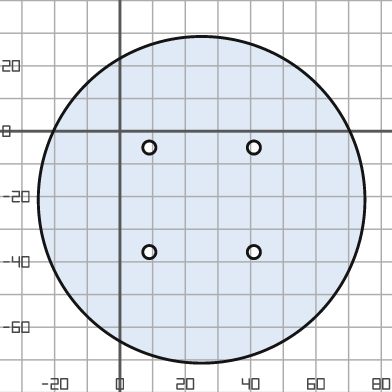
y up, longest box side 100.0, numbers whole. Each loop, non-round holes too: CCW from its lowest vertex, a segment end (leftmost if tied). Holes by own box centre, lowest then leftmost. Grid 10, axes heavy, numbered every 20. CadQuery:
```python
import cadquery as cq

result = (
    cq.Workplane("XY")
    .moveTo(25.0, -21.0)
    .circle(50.0)
    .moveTo(9.0, -37.0)
    .circle(2.0)
    .moveTo(41.0, -37.0)
    .circle(2.0)
    .moveTo(9.0, -5.0)
    .circle(2.0)
    .moveTo(41.0, -5.0)
    .circle(2.0)
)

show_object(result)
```